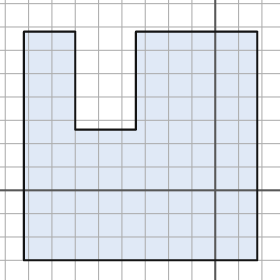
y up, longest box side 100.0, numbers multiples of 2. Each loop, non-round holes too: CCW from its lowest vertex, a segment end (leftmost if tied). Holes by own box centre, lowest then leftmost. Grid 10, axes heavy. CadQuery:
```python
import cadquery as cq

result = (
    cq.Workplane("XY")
    .moveTo(-82.0, -30.0)
    .lineTo(18.0, -30.0)
    .lineTo(18.0, 68.0)
    .lineTo(-34.0, 68.0)
    .lineTo(-34.0, 26.0)
    .lineTo(-60.0, 26.0)
    .lineTo(-60.0, 68.0)
    .lineTo(-82.0, 68.0)
    .close()
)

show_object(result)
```